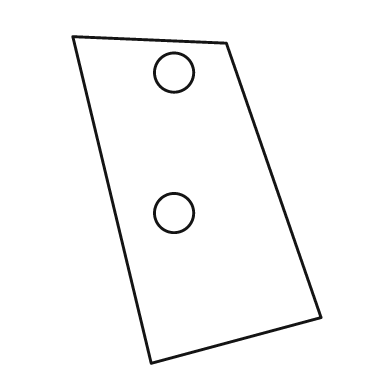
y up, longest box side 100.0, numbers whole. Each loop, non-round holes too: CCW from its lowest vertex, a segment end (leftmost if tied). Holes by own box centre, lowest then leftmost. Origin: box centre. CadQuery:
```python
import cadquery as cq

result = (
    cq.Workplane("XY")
    .moveTo(-14.0, -50.0)
    .lineTo(38.0, -36.0)
    .lineTo(9.0, 48.0)
    .lineTo(-38.0, 50.0)
    .close()
    .moveTo(-7.0, -4.0)
    .circle(6.0)
    .moveTo(-7.0, 39.0)
    .circle(6.0)
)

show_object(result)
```